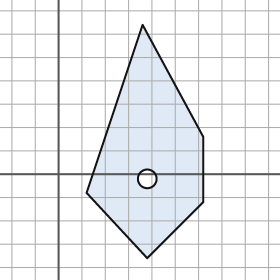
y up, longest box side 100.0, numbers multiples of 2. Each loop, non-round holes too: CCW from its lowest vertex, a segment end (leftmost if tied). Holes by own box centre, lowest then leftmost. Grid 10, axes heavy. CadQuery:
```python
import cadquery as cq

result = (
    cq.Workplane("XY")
    .moveTo(38.0, -36.0)
    .lineTo(62.0, -12.0)
    .lineTo(62.0, 16.0)
    .lineTo(36.0, 64.0)
    .lineTo(12.0, -8.0)
    .close()
    .moveTo(38.0, -2.0)
    .circle(4.0)
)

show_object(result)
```